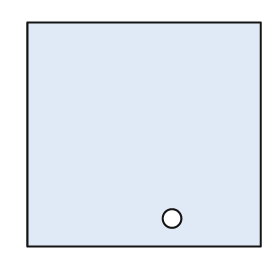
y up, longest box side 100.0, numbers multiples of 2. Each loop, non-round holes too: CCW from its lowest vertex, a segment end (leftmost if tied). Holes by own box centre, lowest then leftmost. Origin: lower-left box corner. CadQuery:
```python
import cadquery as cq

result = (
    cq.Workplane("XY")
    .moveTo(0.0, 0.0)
    .lineTo(100.0, 0.0)
    .lineTo(100.0, 96.0)
    .lineTo(0.0, 96.0)
    .close()
    .moveTo(62.0, 12.0)
    .circle(4.0)
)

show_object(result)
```